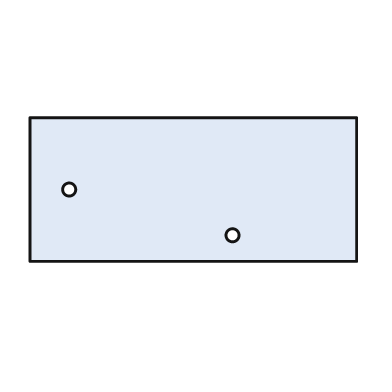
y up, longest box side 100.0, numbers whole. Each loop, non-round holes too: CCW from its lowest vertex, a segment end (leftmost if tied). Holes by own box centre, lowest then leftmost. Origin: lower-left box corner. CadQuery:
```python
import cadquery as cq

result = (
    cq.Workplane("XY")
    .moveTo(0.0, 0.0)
    .lineTo(100.0, 0.0)
    .lineTo(100.0, 44.0)
    .lineTo(0.0, 44.0)
    .close()
    .moveTo(62.0, 8.0)
    .circle(2.0)
    .moveTo(12.0, 22.0)
    .circle(2.0)
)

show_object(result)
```